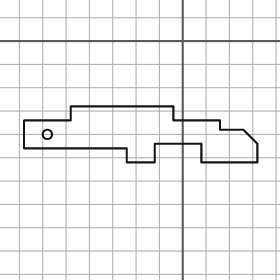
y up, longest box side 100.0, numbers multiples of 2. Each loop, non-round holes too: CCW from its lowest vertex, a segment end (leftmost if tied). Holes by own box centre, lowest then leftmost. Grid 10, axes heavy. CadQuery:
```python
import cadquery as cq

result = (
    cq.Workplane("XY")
    .moveTo(-24.0, -52.0)
    .lineTo(-12.0, -52.0)
    .lineTo(-12.0, -44.0)
    .lineTo(8.0, -44.0)
    .lineTo(8.0, -52.0)
    .lineTo(32.0, -52.0)
    .lineTo(32.0, -44.0)
    .lineTo(26.0, -38.0)
    .lineTo(16.0, -38.0)
    .lineTo(16.0, -34.0)
    .lineTo(-4.0, -34.0)
    .lineTo(-4.0, -28.0)
    .lineTo(-48.0, -28.0)
    .lineTo(-48.0, -34.0)
    .lineTo(-68.0, -34.0)
    .lineTo(-68.0, -46.0)
    .lineTo(-24.0, -46.0)
    .close()
    .moveTo(-58.0, -40.0)
    .circle(2.0)
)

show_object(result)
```